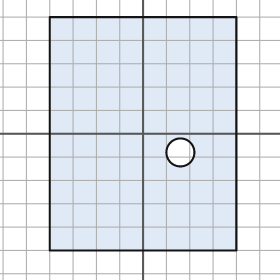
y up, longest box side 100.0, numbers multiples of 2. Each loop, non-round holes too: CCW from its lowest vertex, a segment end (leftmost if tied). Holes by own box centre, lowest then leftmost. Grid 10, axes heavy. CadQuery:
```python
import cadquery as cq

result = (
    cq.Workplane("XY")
    .moveTo(-40.0, -50.0)
    .lineTo(40.0, -50.0)
    .lineTo(40.0, 50.0)
    .lineTo(-40.0, 50.0)
    .close()
    .moveTo(16.0, -8.0)
    .circle(6.0)
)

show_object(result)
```